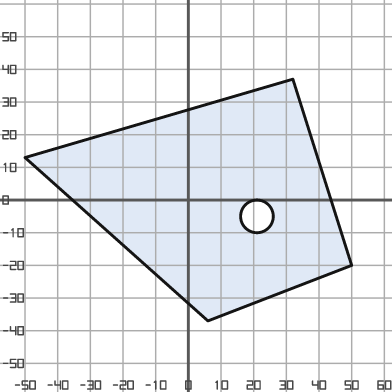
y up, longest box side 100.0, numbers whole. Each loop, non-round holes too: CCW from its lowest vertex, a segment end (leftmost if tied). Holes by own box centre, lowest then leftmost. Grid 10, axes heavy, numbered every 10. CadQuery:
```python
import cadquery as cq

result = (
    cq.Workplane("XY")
    .moveTo(6.0, -37.0)
    .lineTo(50.0, -20.0)
    .lineTo(32.0, 37.0)
    .lineTo(-50.0, 13.0)
    .close()
    .moveTo(21.0, -5.0)
    .circle(5.0)
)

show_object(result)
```